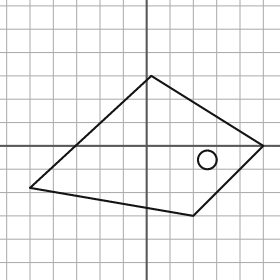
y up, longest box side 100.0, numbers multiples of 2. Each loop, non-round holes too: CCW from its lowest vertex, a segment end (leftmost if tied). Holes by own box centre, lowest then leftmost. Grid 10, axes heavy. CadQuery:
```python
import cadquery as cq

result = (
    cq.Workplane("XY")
    .moveTo(20.0, -30.0)
    .lineTo(50.0, 0.0)
    .lineTo(2.0, 30.0)
    .lineTo(-50.0, -18.0)
    .close()
    .moveTo(26.0, -6.0)
    .circle(4.0)
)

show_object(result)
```